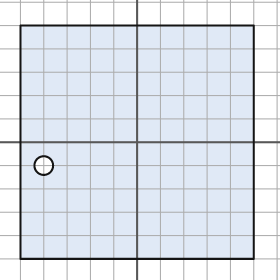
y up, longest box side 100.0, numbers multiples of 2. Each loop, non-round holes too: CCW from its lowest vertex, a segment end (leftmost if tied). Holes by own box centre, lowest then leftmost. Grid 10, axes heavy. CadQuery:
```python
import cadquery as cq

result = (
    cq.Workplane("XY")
    .moveTo(-50.0, -50.0)
    .lineTo(50.0, -50.0)
    .lineTo(50.0, 50.0)
    .lineTo(-50.0, 50.0)
    .close()
    .moveTo(-40.0, -10.0)
    .circle(4.0)
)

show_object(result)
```